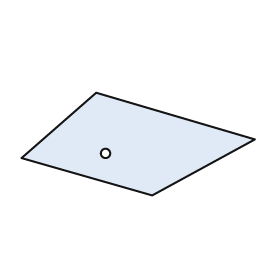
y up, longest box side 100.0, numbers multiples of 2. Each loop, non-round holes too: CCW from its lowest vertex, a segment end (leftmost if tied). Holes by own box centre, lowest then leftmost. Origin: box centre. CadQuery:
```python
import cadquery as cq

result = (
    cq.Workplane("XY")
    .moveTo(6.0, -22.0)
    .lineTo(50.0, 2.0)
    .lineTo(-18.0, 22.0)
    .lineTo(-50.0, -6.0)
    .close()
    .moveTo(-14.0, -4.0)
    .circle(2.0)
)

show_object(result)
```